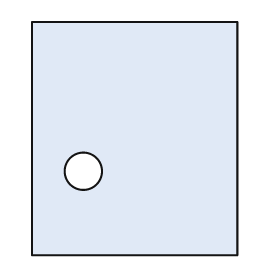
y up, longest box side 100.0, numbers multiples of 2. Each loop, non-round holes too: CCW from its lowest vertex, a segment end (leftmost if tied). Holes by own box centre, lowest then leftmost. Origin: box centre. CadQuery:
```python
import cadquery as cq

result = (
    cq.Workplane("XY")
    .moveTo(-44.0, -50.0)
    .lineTo(44.0, -50.0)
    .lineTo(44.0, 50.0)
    .lineTo(-44.0, 50.0)
    .close()
    .moveTo(-22.0, -14.0)
    .circle(8.0)
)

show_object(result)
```